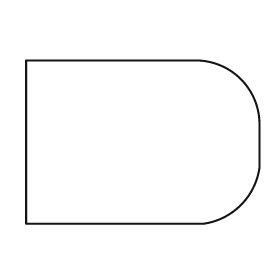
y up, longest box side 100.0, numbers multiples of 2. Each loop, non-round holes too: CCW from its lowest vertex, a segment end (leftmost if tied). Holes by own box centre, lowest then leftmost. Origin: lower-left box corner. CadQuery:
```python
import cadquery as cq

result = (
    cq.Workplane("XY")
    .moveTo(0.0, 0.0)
    .lineTo(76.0, 0.0)
    .threePointArc((92.0, 8.0), (100.0, 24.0))
    .lineTo(100.0, 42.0)
    .threePointArc((92.0, 62.0), (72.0, 70.0))
    .lineTo(0.0, 70.0)
    .close()
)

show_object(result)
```